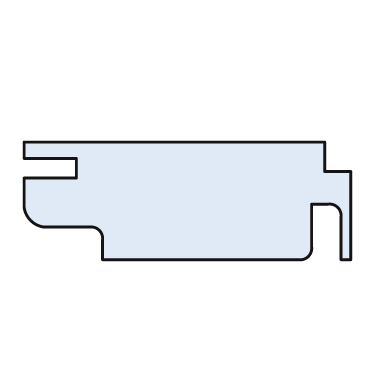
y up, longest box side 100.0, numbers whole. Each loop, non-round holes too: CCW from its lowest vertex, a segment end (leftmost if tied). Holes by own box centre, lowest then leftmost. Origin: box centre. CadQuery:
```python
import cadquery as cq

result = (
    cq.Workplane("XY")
    .moveTo(-26.0, -18.0)
    .lineTo(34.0, -18.0)
    .threePointArc((37.0, -17.0), (38.0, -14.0))
    .lineTo(38.0, -1.0)
    .lineTo(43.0, -1.0)
    .threePointArc((46.0, -2.0), (47.0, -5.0))
    .lineTo(47.0, -18.0)
    .lineTo(50.0, -18.0)
    .lineTo(50.0, 9.0)
    .lineTo(42.0, 9.0)
    .lineTo(42.0, 18.0)
    .lineTo(-50.0, 18.0)
    .lineTo(-50.0, 13.0)
    .lineTo(-34.0, 13.0)
    .lineTo(-34.0, 7.0)
    .lineTo(-50.0, 7.0)
    .lineTo(-50.0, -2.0)
    .threePointArc((-48.0, -6.0), (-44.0, -8.0))
    .lineTo(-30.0, -8.0)
    .threePointArc((-27.0, -9.0), (-26.0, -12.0))
    .close()
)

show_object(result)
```